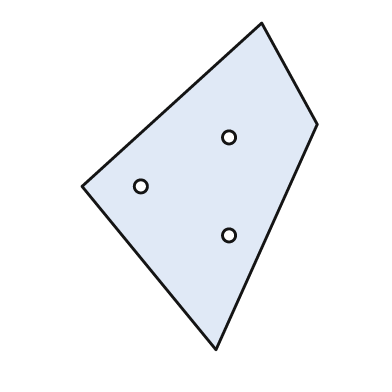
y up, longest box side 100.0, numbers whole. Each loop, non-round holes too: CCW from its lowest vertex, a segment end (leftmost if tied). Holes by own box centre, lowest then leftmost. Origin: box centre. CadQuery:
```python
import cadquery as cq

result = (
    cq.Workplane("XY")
    .moveTo(5.0, -50.0)
    .lineTo(36.0, 19.0)
    .lineTo(19.0, 50.0)
    .lineTo(-36.0, 0.0)
    .close()
    .moveTo(9.0, -15.0)
    .circle(2.0)
    .moveTo(-18.0, 0.0)
    .circle(2.0)
    .moveTo(9.0, 15.0)
    .circle(2.0)
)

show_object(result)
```